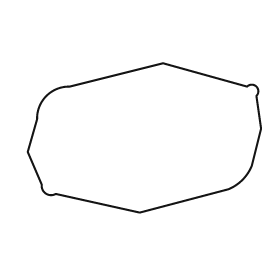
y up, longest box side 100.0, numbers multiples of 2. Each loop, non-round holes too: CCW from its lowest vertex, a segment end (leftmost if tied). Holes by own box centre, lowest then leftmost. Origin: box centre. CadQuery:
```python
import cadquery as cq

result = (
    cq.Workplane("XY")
    .moveTo(-2.0, -32.0)
    .lineTo(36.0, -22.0)
    .threePointArc((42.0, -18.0), (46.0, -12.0))
    .lineTo(50.0, 4.0)
    .lineTo(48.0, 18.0)
    .threePointArc((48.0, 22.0), (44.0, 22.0))
    .lineTo(8.0, 32.0)
    .lineTo(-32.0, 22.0)
    .threePointArc((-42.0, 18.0), (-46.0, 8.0))
    .lineTo(-50.0, -6.0)
    .lineTo(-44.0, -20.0)
    .threePointArc((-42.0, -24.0), (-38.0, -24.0))
    .close()
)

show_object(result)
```